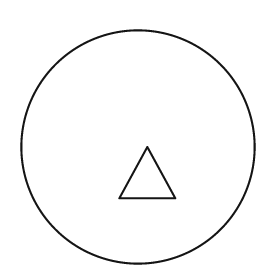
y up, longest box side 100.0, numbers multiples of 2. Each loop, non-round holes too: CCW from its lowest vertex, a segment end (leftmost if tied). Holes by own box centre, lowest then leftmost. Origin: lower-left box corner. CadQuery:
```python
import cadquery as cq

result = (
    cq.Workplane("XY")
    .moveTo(50.0, 50.0)
    .circle(50.0)
    .moveTo(42.0, 28.0)
    .lineTo(66.0, 28.0)
    .lineTo(54.0, 50.0)
    .close()
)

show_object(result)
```